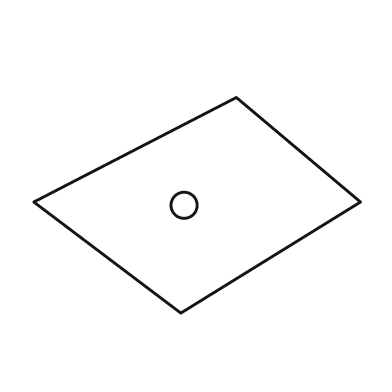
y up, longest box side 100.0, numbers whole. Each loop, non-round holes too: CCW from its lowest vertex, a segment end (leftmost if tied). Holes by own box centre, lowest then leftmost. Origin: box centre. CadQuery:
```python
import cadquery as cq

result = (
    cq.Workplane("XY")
    .moveTo(-5.0, -33.0)
    .lineTo(50.0, 1.0)
    .lineTo(12.0, 33.0)
    .lineTo(-50.0, 1.0)
    .close()
    .moveTo(-4.0, 0.0)
    .circle(4.0)
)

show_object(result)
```